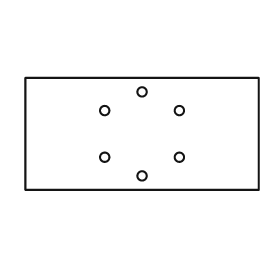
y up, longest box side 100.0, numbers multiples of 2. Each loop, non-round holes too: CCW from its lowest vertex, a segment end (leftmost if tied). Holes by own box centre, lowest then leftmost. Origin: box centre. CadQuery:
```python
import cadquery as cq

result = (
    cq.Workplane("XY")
    .moveTo(-50.0, -24.0)
    .lineTo(50.0, -24.0)
    .lineTo(50.0, 24.0)
    .lineTo(-50.0, 24.0)
    .close()
    .moveTo(0.0, -18.0)
    .circle(2.0)
    .moveTo(-16.0, -10.0)
    .circle(2.0)
    .moveTo(16.0, -10.0)
    .circle(2.0)
    .moveTo(-16.0, 10.0)
    .circle(2.0)
    .moveTo(16.0, 10.0)
    .circle(2.0)
    .moveTo(0.0, 18.0)
    .circle(2.0)
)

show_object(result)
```